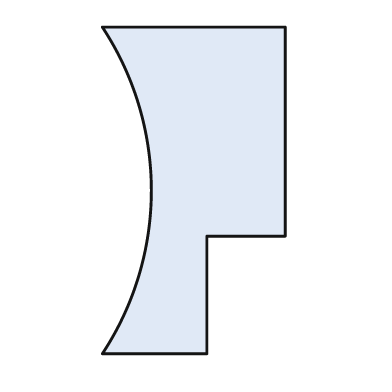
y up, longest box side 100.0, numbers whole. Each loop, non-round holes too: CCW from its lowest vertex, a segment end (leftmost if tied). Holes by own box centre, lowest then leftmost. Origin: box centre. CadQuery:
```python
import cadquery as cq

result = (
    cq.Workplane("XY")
    .moveTo(-28.0, -50.0)
    .lineTo(4.0, -50.0)
    .lineTo(4.0, -14.0)
    .lineTo(28.0, -14.0)
    .lineTo(28.0, 50.0)
    .lineTo(-28.0, 50.0)
    .threePointArc((-13.0, 0.0), (-28.0, -50.0))
    .close()
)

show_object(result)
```